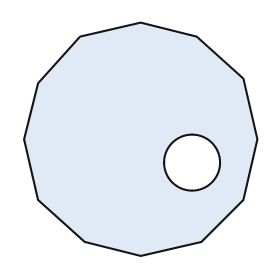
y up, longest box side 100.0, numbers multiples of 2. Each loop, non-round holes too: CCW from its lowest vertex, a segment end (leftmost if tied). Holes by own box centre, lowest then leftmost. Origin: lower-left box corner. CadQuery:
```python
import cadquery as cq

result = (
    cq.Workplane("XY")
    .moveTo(50.0, 0.0)
    .lineTo(76.0, 6.0)
    .lineTo(94.0, 24.0)
    .lineTo(100.0, 50.0)
    .lineTo(94.0, 76.0)
    .lineTo(74.0, 94.0)
    .lineTo(50.0, 100.0)
    .lineTo(24.0, 94.0)
    .lineTo(6.0, 74.0)
    .lineTo(0.0, 50.0)
    .lineTo(6.0, 24.0)
    .lineTo(26.0, 6.0)
    .close()
    .moveTo(72.0, 40.0)
    .circle(12.0)
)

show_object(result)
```